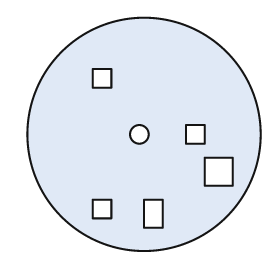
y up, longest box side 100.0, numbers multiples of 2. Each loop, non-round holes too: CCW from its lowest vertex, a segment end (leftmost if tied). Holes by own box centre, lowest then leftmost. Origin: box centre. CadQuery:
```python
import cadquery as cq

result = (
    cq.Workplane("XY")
    .moveTo(0.0, 0.0)
    .circle(50.0)
    .moveTo(0.0, -40.0)
    .lineTo(8.0, -40.0)
    .lineTo(8.0, -28.0)
    .lineTo(0.0, -28.0)
    .close()
    .moveTo(-22.0, -36.0)
    .lineTo(-14.0, -36.0)
    .lineTo(-14.0, -28.0)
    .lineTo(-22.0, -28.0)
    .close()
    .moveTo(26.0, -22.0)
    .lineTo(38.0, -22.0)
    .lineTo(38.0, -10.0)
    .lineTo(26.0, -10.0)
    .close()
    .moveTo(-2.0, 0.0)
    .circle(4.0)
    .moveTo(18.0, -4.0)
    .lineTo(26.0, -4.0)
    .lineTo(26.0, 4.0)
    .lineTo(18.0, 4.0)
    .close()
    .moveTo(-22.0, 20.0)
    .lineTo(-14.0, 20.0)
    .lineTo(-14.0, 28.0)
    .lineTo(-22.0, 28.0)
    .close()
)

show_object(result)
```